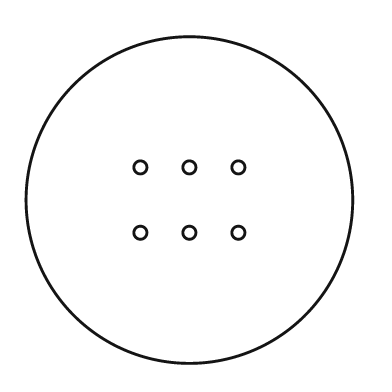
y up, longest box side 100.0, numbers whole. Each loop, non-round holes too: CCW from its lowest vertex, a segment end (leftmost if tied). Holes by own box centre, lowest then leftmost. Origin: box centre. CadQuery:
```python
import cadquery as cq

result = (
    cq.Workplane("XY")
    .moveTo(0.0, 0.0)
    .circle(50.0)
    .moveTo(-15.0, -10.0)
    .circle(2.0)
    .moveTo(0.0, -10.0)
    .circle(2.0)
    .moveTo(15.0, -10.0)
    .circle(2.0)
    .moveTo(-15.0, 10.0)
    .circle(2.0)
    .moveTo(0.0, 10.0)
    .circle(2.0)
    .moveTo(15.0, 10.0)
    .circle(2.0)
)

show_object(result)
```